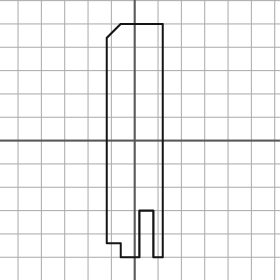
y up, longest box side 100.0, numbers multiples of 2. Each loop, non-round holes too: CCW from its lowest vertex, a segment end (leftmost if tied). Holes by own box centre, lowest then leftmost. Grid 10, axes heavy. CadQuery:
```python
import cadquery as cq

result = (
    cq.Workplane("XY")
    .moveTo(-6.0, -50.0)
    .lineTo(2.0, -50.0)
    .lineTo(2.0, -30.0)
    .lineTo(8.0, -30.0)
    .lineTo(8.0, -50.0)
    .lineTo(12.0, -50.0)
    .lineTo(12.0, 50.0)
    .lineTo(-6.0, 50.0)
    .lineTo(-12.0, 44.0)
    .lineTo(-12.0, -44.0)
    .lineTo(-6.0, -44.0)
    .close()
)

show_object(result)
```